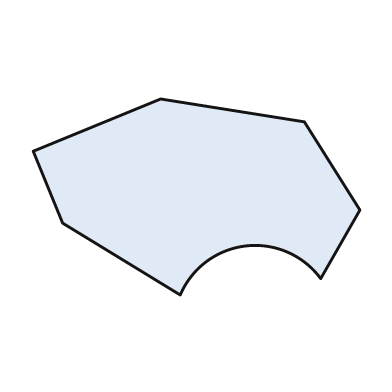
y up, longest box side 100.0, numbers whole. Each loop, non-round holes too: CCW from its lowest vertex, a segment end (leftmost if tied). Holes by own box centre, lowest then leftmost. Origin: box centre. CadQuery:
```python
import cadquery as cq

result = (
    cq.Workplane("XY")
    .moveTo(-5.0, -30.0)
    .threePointArc((15.0, -15.0), (38.0, -25.0))
    .lineTo(50.0, -4.0)
    .lineTo(33.0, 23.0)
    .lineTo(-11.0, 30.0)
    .lineTo(-50.0, 14.0)
    .lineTo(-41.0, -8.0)
    .close()
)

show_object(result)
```